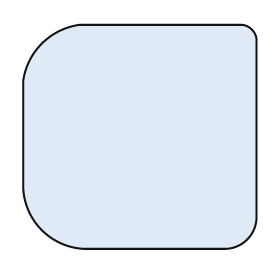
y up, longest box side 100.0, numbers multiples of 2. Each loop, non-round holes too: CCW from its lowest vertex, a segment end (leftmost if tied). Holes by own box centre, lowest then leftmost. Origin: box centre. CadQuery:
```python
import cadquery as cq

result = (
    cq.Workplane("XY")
    .moveTo(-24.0, -48.0)
    .lineTo(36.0, -48.0)
    .threePointArc((46.0, -44.0), (50.0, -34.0))
    .lineTo(50.0, 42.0)
    .threePointArc((48.0, 46.0), (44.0, 48.0))
    .lineTo(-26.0, 48.0)
    .threePointArc((-42.0, 40.0), (-50.0, 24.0))
    .lineTo(-50.0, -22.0)
    .threePointArc((-42.0, -40.0), (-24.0, -48.0))
    .close()
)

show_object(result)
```